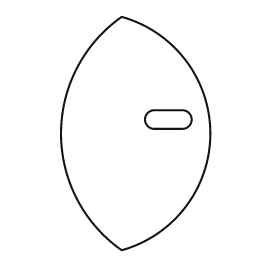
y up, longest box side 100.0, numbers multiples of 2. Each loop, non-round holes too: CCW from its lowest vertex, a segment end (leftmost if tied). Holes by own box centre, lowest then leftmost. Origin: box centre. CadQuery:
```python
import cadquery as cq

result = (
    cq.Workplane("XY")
    .moveTo(-6.0, -50.0)
    .threePointArc((32.0, 0.0), (-6.0, 50.0))
    .threePointArc((-32.0, 0.0), (-6.0, -50.0))
    .close()
    .moveTo(8.0, 2.0)
    .lineTo(20.0, 2.0)
    .threePointArc((24.0, 6.0), (20.0, 10.0))
    .lineTo(8.0, 10.0)
    .threePointArc((4.0, 6.0), (8.0, 2.0))
    .close()
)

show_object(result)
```